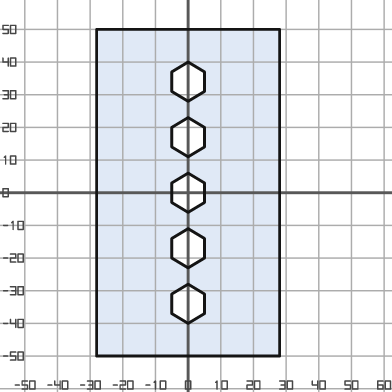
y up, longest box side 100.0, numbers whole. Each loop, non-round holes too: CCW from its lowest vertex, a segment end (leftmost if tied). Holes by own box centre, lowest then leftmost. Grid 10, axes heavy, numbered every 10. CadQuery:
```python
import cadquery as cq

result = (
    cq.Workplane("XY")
    .moveTo(-28.0, -50.0)
    .lineTo(28.0, -50.0)
    .lineTo(28.0, 50.0)
    .lineTo(-28.0, 50.0)
    .close()
    .moveTo(0.0, -40.0)
    .lineTo(5.0, -37.0)
    .lineTo(5.0, -31.0)
    .lineTo(0.0, -28.0)
    .lineTo(-5.0, -31.0)
    .lineTo(-5.0, -37.0)
    .close()
    .moveTo(0.0, -23.0)
    .lineTo(5.0, -20.0)
    .lineTo(5.0, -14.0)
    .lineTo(0.0, -11.0)
    .lineTo(-5.0, -14.0)
    .lineTo(-5.0, -20.0)
    .close()
    .moveTo(0.0, -6.0)
    .lineTo(5.0, -3.0)
    .lineTo(5.0, 3.0)
    .lineTo(0.0, 6.0)
    .lineTo(-5.0, 3.0)
    .lineTo(-5.0, -3.0)
    .close()
    .moveTo(0.0, 11.0)
    .lineTo(5.0, 14.0)
    .lineTo(5.0, 20.0)
    .lineTo(0.0, 23.0)
    .lineTo(-5.0, 20.0)
    .lineTo(-5.0, 14.0)
    .close()
    .moveTo(0.0, 28.0)
    .lineTo(5.0, 31.0)
    .lineTo(5.0, 37.0)
    .lineTo(0.0, 40.0)
    .lineTo(-5.0, 37.0)
    .lineTo(-5.0, 31.0)
    .close()
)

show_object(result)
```